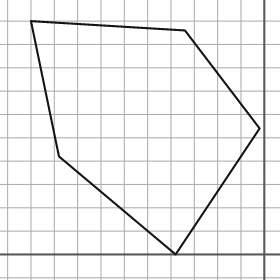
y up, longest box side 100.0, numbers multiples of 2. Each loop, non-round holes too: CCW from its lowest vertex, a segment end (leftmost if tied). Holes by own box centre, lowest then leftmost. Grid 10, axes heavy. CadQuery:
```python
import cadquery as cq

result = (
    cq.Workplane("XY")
    .moveTo(-38.0, 0.0)
    .lineTo(-2.0, 54.0)
    .lineTo(-34.0, 96.0)
    .lineTo(-100.0, 100.0)
    .lineTo(-88.0, 42.0)
    .close()
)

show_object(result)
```